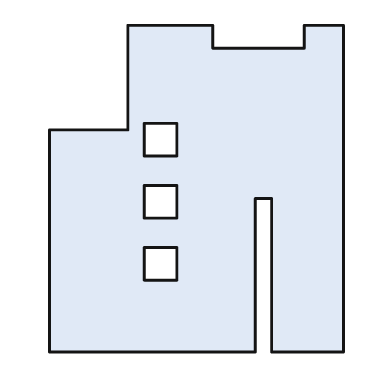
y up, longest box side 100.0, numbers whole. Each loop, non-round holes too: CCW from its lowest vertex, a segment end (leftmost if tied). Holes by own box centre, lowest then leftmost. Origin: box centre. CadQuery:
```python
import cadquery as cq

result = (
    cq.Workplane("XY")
    .moveTo(-45.0, -50.0)
    .lineTo(18.0, -50.0)
    .lineTo(18.0, -3.0)
    .lineTo(23.0, -3.0)
    .lineTo(23.0, -50.0)
    .lineTo(45.0, -50.0)
    .lineTo(45.0, 50.0)
    .lineTo(33.0, 50.0)
    .lineTo(33.0, 43.0)
    .lineTo(5.0, 43.0)
    .lineTo(5.0, 50.0)
    .lineTo(-21.0, 50.0)
    .lineTo(-21.0, 18.0)
    .lineTo(-45.0, 18.0)
    .close()
    .moveTo(-16.0, -28.0)
    .lineTo(-6.0, -28.0)
    .lineTo(-6.0, -18.0)
    .lineTo(-16.0, -18.0)
    .close()
    .moveTo(-16.0, -9.0)
    .lineTo(-6.0, -9.0)
    .lineTo(-6.0, 1.0)
    .lineTo(-16.0, 1.0)
    .close()
    .moveTo(-16.0, 10.0)
    .lineTo(-6.0, 10.0)
    .lineTo(-6.0, 20.0)
    .lineTo(-16.0, 20.0)
    .close()
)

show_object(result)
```